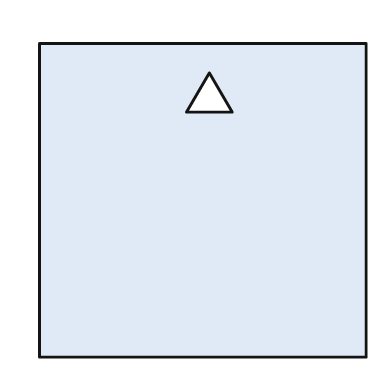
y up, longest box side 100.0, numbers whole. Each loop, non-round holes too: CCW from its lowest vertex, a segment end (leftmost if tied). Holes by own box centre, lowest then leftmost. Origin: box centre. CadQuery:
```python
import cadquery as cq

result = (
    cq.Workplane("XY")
    .moveTo(-50.0, -48.0)
    .lineTo(50.0, -48.0)
    .lineTo(50.0, 48.0)
    .lineTo(-50.0, 48.0)
    .close()
    .moveTo(-5.0, 27.0)
    .lineTo(9.0, 27.0)
    .lineTo(2.0, 39.0)
    .close()
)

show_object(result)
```